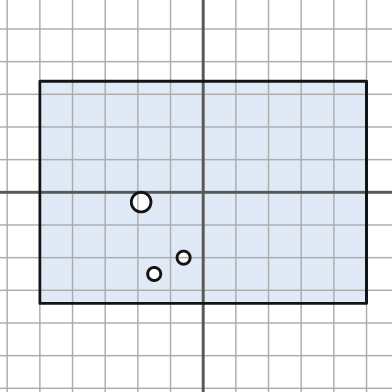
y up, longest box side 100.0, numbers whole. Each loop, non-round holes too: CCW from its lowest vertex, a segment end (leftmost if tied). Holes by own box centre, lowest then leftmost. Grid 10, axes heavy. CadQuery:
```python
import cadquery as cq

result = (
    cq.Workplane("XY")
    .moveTo(-50.0, -34.0)
    .lineTo(50.0, -34.0)
    .lineTo(50.0, 34.0)
    .lineTo(-50.0, 34.0)
    .close()
    .moveTo(-15.0, -25.0)
    .circle(2.0)
    .moveTo(-6.0, -20.0)
    .circle(2.0)
    .moveTo(-19.0, -3.0)
    .circle(3.0)
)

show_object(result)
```